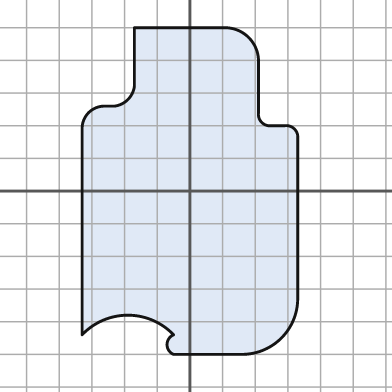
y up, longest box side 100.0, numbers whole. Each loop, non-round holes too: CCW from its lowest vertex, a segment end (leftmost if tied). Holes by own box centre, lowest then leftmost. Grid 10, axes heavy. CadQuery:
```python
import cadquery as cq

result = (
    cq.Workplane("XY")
    .moveTo(-5.0, -50.0)
    .lineTo(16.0, -50.0)
    .threePointArc((28.0, -45.0), (33.0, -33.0))
    .lineTo(33.0, 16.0)
    .threePointArc((32.0, 19.0), (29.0, 20.0))
    .lineTo(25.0, 20.0)
    .threePointArc((22.0, 21.0), (21.0, 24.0))
    .lineTo(21.0, 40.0)
    .threePointArc((18.0, 47.0), (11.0, 50.0))
    .lineTo(-17.0, 50.0)
    .lineTo(-17.0, 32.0)
    .threePointArc((-19.0, 28.0), (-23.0, 26.0))
    .lineTo(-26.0, 26.0)
    .threePointArc((-31.0, 24.0), (-33.0, 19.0))
    .lineTo(-33.0, -44.0)
    .threePointArc((-19.0, -38.0), (-5.0, -44.0))
    .threePointArc((-7.0, -47.0), (-5.0, -50.0))
    .close()
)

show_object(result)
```